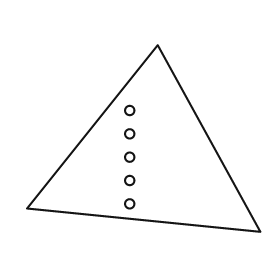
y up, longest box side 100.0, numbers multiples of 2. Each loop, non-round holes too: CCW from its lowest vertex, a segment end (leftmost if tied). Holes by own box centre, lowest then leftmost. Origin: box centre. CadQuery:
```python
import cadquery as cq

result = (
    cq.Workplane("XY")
    .moveTo(50.0, -40.0)
    .lineTo(6.0, 40.0)
    .lineTo(-50.0, -30.0)
    .close()
    .moveTo(-6.0, -28.0)
    .circle(2.0)
    .moveTo(-6.0, -18.0)
    .circle(2.0)
    .moveTo(-6.0, -8.0)
    .circle(2.0)
    .moveTo(-6.0, 2.0)
    .circle(2.0)
    .moveTo(-6.0, 12.0)
    .circle(2.0)
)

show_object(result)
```